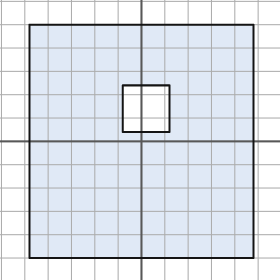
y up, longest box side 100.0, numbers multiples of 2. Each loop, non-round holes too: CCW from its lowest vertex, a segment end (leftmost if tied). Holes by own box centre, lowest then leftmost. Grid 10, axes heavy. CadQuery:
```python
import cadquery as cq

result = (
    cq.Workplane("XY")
    .moveTo(-48.0, -50.0)
    .lineTo(48.0, -50.0)
    .lineTo(48.0, 50.0)
    .lineTo(-48.0, 50.0)
    .close()
    .moveTo(-8.0, 4.0)
    .lineTo(12.0, 4.0)
    .lineTo(12.0, 24.0)
    .lineTo(-8.0, 24.0)
    .close()
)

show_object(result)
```